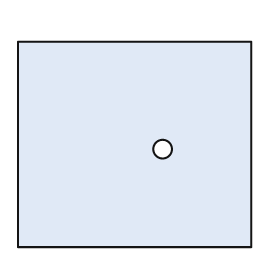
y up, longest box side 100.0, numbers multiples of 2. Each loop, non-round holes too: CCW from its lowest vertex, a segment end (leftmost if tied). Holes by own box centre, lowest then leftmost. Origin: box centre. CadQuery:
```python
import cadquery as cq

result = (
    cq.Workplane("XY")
    .moveTo(-50.0, -44.0)
    .lineTo(50.0, -44.0)
    .lineTo(50.0, 44.0)
    .lineTo(-50.0, 44.0)
    .close()
    .moveTo(12.0, -2.0)
    .circle(4.0)
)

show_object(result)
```